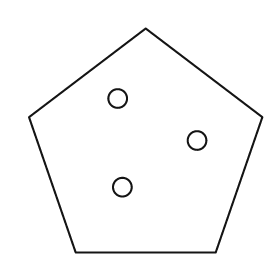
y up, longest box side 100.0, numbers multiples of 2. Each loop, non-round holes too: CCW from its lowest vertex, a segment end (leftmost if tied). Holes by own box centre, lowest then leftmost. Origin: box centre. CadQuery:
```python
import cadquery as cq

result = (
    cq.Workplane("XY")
    .moveTo(-30.0, -48.0)
    .lineTo(30.0, -48.0)
    .lineTo(50.0, 10.0)
    .lineTo(0.0, 48.0)
    .lineTo(-50.0, 10.0)
    .close()
    .moveTo(-10.0, -20.0)
    .circle(4.0)
    .moveTo(22.0, 0.0)
    .circle(4.0)
    .moveTo(-12.0, 18.0)
    .circle(4.0)
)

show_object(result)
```